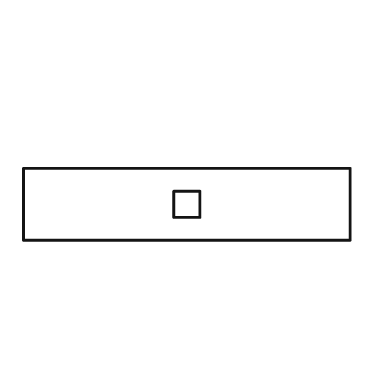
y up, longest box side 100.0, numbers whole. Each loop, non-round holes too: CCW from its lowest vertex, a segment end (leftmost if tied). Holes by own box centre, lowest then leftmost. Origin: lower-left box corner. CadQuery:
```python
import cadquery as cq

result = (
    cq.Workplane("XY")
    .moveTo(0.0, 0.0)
    .lineTo(100.0, 0.0)
    .lineTo(100.0, 22.0)
    .lineTo(0.0, 22.0)
    .close()
    .moveTo(46.0, 7.0)
    .lineTo(54.0, 7.0)
    .lineTo(54.0, 15.0)
    .lineTo(46.0, 15.0)
    .close()
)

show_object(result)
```